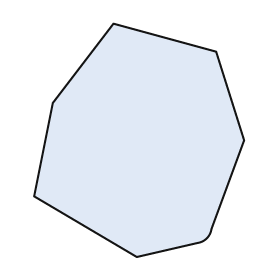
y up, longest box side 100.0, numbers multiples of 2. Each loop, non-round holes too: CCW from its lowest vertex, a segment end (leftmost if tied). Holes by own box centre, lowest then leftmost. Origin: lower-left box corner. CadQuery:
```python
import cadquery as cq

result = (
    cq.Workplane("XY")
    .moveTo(44.0, 0.0)
    .lineTo(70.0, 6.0)
    .threePointArc((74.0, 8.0), (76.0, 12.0))
    .lineTo(90.0, 50.0)
    .lineTo(78.0, 88.0)
    .lineTo(34.0, 100.0)
    .lineTo(8.0, 66.0)
    .lineTo(0.0, 26.0)
    .close()
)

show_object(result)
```